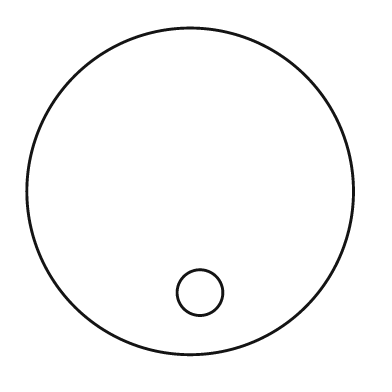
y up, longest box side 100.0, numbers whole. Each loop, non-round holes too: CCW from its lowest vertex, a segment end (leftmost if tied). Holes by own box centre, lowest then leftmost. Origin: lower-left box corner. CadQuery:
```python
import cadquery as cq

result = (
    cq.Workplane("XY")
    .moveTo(50.0, 50.0)
    .circle(50.0)
    .moveTo(53.0, 19.0)
    .circle(7.0)
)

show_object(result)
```